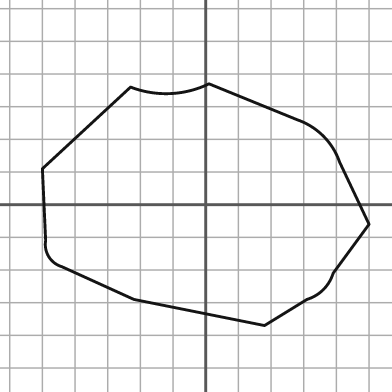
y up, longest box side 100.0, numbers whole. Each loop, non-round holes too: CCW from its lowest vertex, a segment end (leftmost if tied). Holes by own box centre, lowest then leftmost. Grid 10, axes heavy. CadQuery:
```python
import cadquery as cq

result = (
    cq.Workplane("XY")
    .moveTo(18.0, -37.0)
    .lineTo(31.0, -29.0)
    .threePointArc((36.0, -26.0), (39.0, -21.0))
    .lineTo(50.0, -6.0)
    .lineTo(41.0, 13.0)
    .threePointArc((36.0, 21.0), (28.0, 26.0))
    .lineTo(1.0, 37.0)
    .threePointArc((-11.0, 34.0), (-23.0, 36.0))
    .lineTo(-50.0, 11.0)
    .lineTo(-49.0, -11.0)
    .threePointArc((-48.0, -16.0), (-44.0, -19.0))
    .lineTo(-22.0, -29.0)
    .close()
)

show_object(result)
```